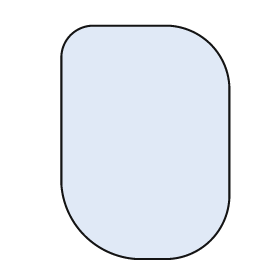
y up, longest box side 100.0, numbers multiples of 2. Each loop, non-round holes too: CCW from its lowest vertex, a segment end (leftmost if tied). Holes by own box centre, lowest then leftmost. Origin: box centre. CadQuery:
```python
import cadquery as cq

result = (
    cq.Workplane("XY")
    .moveTo(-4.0, -50.0)
    .lineTo(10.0, -50.0)
    .threePointArc((28.0, -42.0), (36.0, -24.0))
    .lineTo(36.0, 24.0)
    .threePointArc((28.0, 42.0), (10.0, 50.0))
    .lineTo(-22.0, 50.0)
    .threePointArc((-32.0, 46.0), (-36.0, 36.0))
    .lineTo(-36.0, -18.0)
    .threePointArc((-26.0, -40.0), (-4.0, -50.0))
    .close()
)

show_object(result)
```